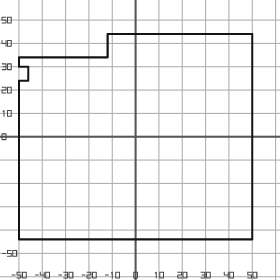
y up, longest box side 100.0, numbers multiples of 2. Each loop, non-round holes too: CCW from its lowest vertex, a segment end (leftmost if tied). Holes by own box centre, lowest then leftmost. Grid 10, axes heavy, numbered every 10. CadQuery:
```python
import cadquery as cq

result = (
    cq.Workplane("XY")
    .moveTo(-50.0, -44.0)
    .lineTo(50.0, -44.0)
    .lineTo(50.0, 44.0)
    .lineTo(-12.0, 44.0)
    .lineTo(-12.0, 34.0)
    .lineTo(-50.0, 34.0)
    .lineTo(-50.0, 30.0)
    .lineTo(-46.0, 30.0)
    .lineTo(-46.0, 24.0)
    .lineTo(-50.0, 24.0)
    .close()
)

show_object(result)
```